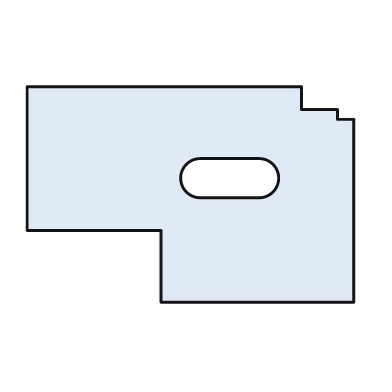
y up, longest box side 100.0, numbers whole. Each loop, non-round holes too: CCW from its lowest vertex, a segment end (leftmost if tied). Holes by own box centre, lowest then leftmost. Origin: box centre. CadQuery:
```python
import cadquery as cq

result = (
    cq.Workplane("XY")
    .moveTo(-9.0, -33.0)
    .lineTo(50.0, -33.0)
    .lineTo(50.0, 23.0)
    .lineTo(45.0, 23.0)
    .lineTo(45.0, 26.0)
    .lineTo(34.0, 26.0)
    .lineTo(34.0, 33.0)
    .lineTo(-50.0, 33.0)
    .lineTo(-50.0, -11.0)
    .lineTo(-9.0, -11.0)
    .close()
    .moveTo(3.0, -1.0)
    .lineTo(21.0, -1.0)
    .threePointArc((27.0, 5.0), (21.0, 11.0))
    .lineTo(3.0, 11.0)
    .threePointArc((-3.0, 5.0), (3.0, -1.0))
    .close()
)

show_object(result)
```